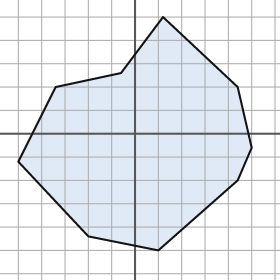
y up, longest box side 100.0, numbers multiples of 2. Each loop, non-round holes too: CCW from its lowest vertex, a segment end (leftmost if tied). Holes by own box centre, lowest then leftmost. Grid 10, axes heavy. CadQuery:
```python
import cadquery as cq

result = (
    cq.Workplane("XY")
    .moveTo(10.0, -50.0)
    .lineTo(44.0, -20.0)
    .lineTo(50.0, -6.0)
    .lineTo(44.0, 20.0)
    .lineTo(12.0, 50.0)
    .lineTo(-6.0, 26.0)
    .lineTo(-34.0, 20.0)
    .lineTo(-50.0, -12.0)
    .lineTo(-20.0, -44.0)
    .close()
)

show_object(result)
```